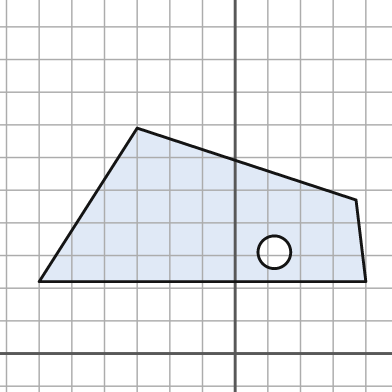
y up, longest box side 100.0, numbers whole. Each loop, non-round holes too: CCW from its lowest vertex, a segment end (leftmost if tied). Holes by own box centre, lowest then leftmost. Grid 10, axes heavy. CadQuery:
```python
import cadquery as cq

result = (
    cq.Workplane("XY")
    .moveTo(-60.0, 22.0)
    .lineTo(40.0, 22.0)
    .lineTo(37.0, 47.0)
    .lineTo(-30.0, 69.0)
    .close()
    .moveTo(12.0, 31.0)
    .circle(5.0)
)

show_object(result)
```